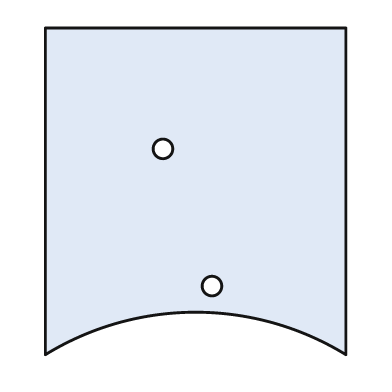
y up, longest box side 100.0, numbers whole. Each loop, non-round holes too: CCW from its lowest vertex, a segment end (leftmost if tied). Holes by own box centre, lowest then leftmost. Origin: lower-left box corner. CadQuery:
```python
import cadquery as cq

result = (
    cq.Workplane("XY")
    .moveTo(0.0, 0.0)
    .threePointArc((46.0, 13.0), (92.0, 0.0))
    .lineTo(92.0, 100.0)
    .lineTo(0.0, 100.0)
    .close()
    .moveTo(51.0, 21.0)
    .circle(3.0)
    .moveTo(36.0, 63.0)
    .circle(3.0)
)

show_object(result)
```